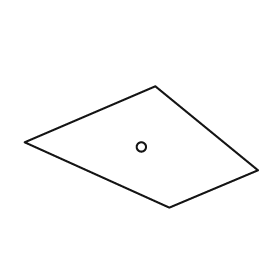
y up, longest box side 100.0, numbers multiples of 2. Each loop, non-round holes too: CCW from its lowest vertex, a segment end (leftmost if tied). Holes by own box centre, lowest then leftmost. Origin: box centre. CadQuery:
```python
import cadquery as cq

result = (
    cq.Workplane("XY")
    .moveTo(12.0, -26.0)
    .lineTo(50.0, -10.0)
    .lineTo(6.0, 26.0)
    .lineTo(-50.0, 2.0)
    .close()
    .moveTo(0.0, 0.0)
    .circle(2.0)
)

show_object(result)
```